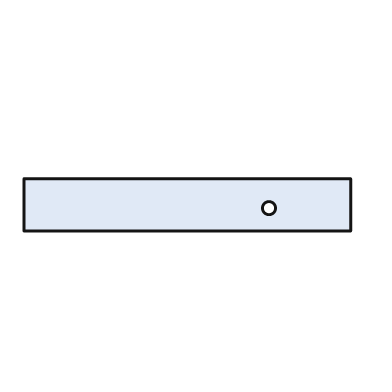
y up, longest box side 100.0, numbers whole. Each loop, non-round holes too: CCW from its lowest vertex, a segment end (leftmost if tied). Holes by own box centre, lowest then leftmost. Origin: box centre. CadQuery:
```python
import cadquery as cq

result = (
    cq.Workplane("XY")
    .moveTo(-50.0, -8.0)
    .lineTo(50.0, -8.0)
    .lineTo(50.0, 8.0)
    .lineTo(-50.0, 8.0)
    .close()
    .moveTo(25.0, -1.0)
    .circle(2.0)
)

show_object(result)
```